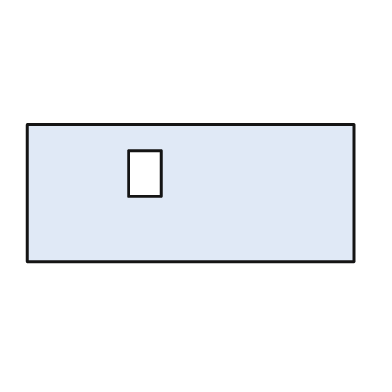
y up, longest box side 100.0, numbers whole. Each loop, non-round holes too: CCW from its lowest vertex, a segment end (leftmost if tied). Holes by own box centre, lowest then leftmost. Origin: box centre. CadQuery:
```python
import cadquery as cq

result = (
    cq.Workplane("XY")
    .moveTo(-50.0, -21.0)
    .lineTo(50.0, -21.0)
    .lineTo(50.0, 21.0)
    .lineTo(-50.0, 21.0)
    .close()
    .moveTo(-19.0, -1.0)
    .lineTo(-9.0, -1.0)
    .lineTo(-9.0, 13.0)
    .lineTo(-19.0, 13.0)
    .close()
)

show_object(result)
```